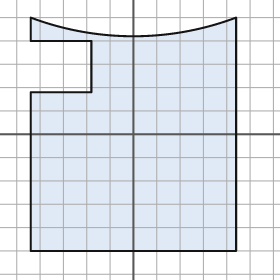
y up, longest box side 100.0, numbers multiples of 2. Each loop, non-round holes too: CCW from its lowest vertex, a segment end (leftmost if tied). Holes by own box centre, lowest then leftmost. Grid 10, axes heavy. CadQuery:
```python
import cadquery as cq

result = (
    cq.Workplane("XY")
    .moveTo(-44.0, -50.0)
    .lineTo(44.0, -50.0)
    .lineTo(44.0, 50.0)
    .threePointArc((0.0, 42.0), (-44.0, 50.0))
    .lineTo(-44.0, 40.0)
    .lineTo(-18.0, 40.0)
    .lineTo(-18.0, 18.0)
    .lineTo(-44.0, 18.0)
    .close()
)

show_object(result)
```